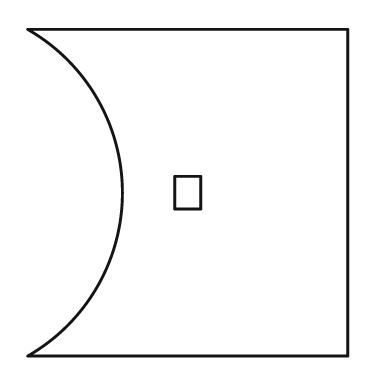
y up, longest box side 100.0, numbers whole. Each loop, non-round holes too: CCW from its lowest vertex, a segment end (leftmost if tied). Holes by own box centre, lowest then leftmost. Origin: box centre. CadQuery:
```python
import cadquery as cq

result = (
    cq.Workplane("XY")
    .moveTo(-49.0, -50.0)
    .lineTo(49.0, -50.0)
    .lineTo(49.0, 50.0)
    .lineTo(-49.0, 50.0)
    .threePointArc((-20.0, 0.0), (-49.0, -50.0))
    .close()
    .moveTo(-4.0, -5.0)
    .lineTo(4.0, -5.0)
    .lineTo(4.0, 5.0)
    .lineTo(-4.0, 5.0)
    .close()
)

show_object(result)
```